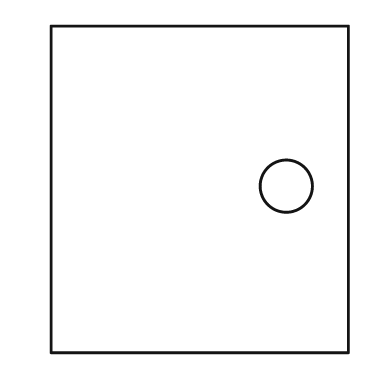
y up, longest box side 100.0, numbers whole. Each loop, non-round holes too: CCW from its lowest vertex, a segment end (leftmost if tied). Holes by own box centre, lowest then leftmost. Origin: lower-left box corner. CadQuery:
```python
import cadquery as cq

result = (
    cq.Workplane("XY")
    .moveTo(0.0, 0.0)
    .lineTo(91.0, 0.0)
    .lineTo(91.0, 100.0)
    .lineTo(0.0, 100.0)
    .close()
    .moveTo(72.0, 51.0)
    .circle(8.0)
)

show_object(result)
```